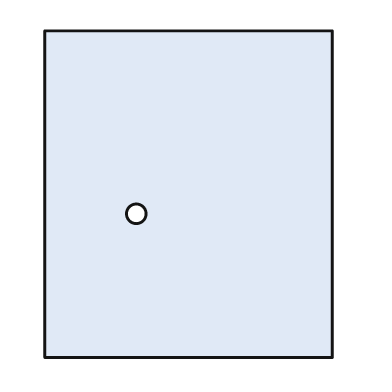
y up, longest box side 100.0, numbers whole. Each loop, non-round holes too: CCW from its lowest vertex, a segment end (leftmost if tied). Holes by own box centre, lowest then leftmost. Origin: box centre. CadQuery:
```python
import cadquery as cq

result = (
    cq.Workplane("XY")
    .moveTo(-44.0, -50.0)
    .lineTo(44.0, -50.0)
    .lineTo(44.0, 50.0)
    .lineTo(-44.0, 50.0)
    .close()
    .moveTo(-16.0, -6.0)
    .circle(3.0)
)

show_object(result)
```